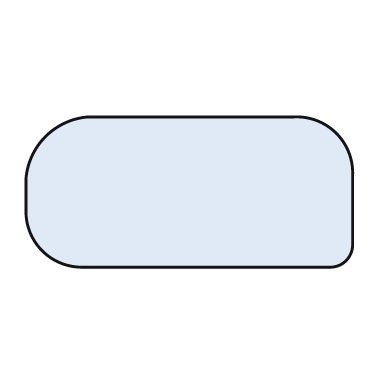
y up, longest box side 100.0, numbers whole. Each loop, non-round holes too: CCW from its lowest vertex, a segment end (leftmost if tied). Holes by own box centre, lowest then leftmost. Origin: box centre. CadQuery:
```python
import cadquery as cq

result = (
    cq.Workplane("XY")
    .moveTo(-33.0, -23.0)
    .lineTo(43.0, -23.0)
    .threePointArc((48.0, -21.0), (50.0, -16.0))
    .lineTo(50.0, 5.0)
    .threePointArc((45.0, 18.0), (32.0, 23.0))
    .lineTo(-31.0, 23.0)
    .threePointArc((-44.0, 17.0), (-50.0, 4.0))
    .lineTo(-50.0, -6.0)
    .threePointArc((-45.0, -18.0), (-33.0, -23.0))
    .close()
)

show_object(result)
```